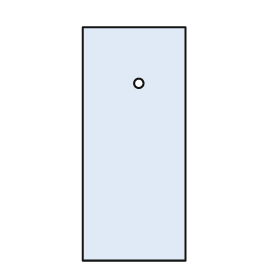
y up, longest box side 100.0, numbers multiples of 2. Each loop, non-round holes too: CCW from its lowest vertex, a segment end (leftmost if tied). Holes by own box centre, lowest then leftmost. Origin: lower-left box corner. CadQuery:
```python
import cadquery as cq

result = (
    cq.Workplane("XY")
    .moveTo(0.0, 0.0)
    .lineTo(44.0, 0.0)
    .lineTo(44.0, 100.0)
    .lineTo(0.0, 100.0)
    .close()
    .moveTo(24.0, 76.0)
    .circle(2.0)
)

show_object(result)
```